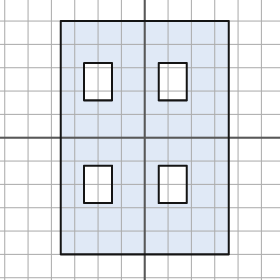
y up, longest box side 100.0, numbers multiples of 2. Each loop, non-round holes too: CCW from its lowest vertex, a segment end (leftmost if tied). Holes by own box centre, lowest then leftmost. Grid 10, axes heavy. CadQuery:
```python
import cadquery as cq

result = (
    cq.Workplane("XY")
    .moveTo(-36.0, -50.0)
    .lineTo(36.0, -50.0)
    .lineTo(36.0, 50.0)
    .lineTo(-36.0, 50.0)
    .close()
    .moveTo(-26.0, -28.0)
    .lineTo(-14.0, -28.0)
    .lineTo(-14.0, -12.0)
    .lineTo(-26.0, -12.0)
    .close()
    .moveTo(6.0, -28.0)
    .lineTo(18.0, -28.0)
    .lineTo(18.0, -12.0)
    .lineTo(6.0, -12.0)
    .close()
    .moveTo(-26.0, 16.0)
    .lineTo(-14.0, 16.0)
    .lineTo(-14.0, 32.0)
    .lineTo(-26.0, 32.0)
    .close()
    .moveTo(6.0, 16.0)
    .lineTo(18.0, 16.0)
    .lineTo(18.0, 32.0)
    .lineTo(6.0, 32.0)
    .close()
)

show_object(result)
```